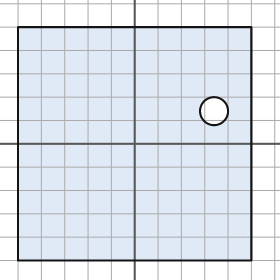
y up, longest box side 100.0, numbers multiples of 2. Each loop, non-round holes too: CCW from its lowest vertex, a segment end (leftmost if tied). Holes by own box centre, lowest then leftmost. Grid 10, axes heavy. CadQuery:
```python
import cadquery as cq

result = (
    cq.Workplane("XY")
    .moveTo(-50.0, -50.0)
    .lineTo(50.0, -50.0)
    .lineTo(50.0, 50.0)
    .lineTo(-50.0, 50.0)
    .close()
    .moveTo(34.0, 14.0)
    .circle(6.0)
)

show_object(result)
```